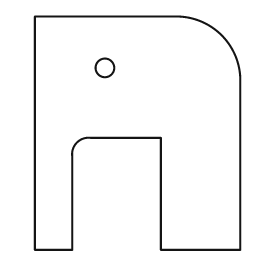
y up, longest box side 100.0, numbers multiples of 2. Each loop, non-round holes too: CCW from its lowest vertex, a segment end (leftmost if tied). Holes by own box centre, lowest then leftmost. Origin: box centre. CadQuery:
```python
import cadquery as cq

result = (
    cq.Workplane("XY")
    .moveTo(-44.0, -50.0)
    .lineTo(-28.0, -50.0)
    .lineTo(-28.0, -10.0)
    .threePointArc((-26.0, -4.0), (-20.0, -2.0))
    .lineTo(10.0, -2.0)
    .lineTo(10.0, -50.0)
    .lineTo(44.0, -50.0)
    .lineTo(44.0, 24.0)
    .threePointArc((36.0, 42.0), (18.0, 50.0))
    .lineTo(-44.0, 50.0)
    .close()
    .moveTo(-14.0, 28.0)
    .circle(4.0)
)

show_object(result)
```